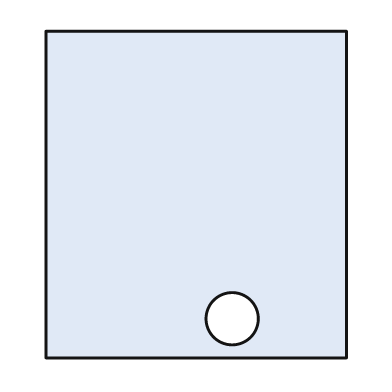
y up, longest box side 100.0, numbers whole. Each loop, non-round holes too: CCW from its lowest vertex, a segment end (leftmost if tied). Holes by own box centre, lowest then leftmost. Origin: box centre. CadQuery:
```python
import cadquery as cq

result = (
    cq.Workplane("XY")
    .moveTo(-46.0, -50.0)
    .lineTo(46.0, -50.0)
    .lineTo(46.0, 50.0)
    .lineTo(-46.0, 50.0)
    .close()
    .moveTo(11.0, -38.0)
    .circle(8.0)
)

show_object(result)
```